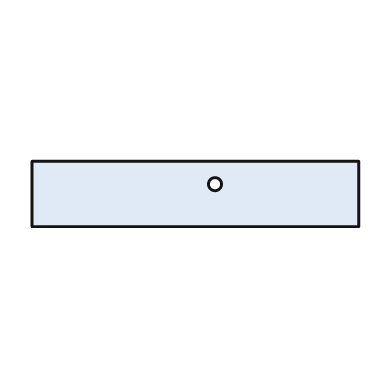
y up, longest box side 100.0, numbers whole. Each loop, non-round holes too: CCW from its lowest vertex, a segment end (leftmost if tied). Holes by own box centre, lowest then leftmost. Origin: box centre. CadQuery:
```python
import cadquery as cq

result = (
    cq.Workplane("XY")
    .moveTo(-50.0, -10.0)
    .lineTo(50.0, -10.0)
    .lineTo(50.0, 10.0)
    .lineTo(-50.0, 10.0)
    .close()
    .moveTo(6.0, 3.0)
    .circle(2.0)
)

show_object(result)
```